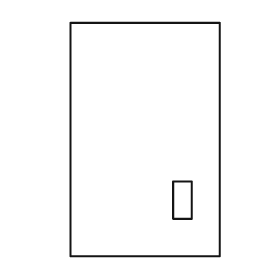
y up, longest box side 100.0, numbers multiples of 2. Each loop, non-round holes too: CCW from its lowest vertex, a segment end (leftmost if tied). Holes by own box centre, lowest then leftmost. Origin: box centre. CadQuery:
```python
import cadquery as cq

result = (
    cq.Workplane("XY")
    .moveTo(-32.0, -50.0)
    .lineTo(32.0, -50.0)
    .lineTo(32.0, 50.0)
    .lineTo(-32.0, 50.0)
    .close()
    .moveTo(12.0, -34.0)
    .lineTo(20.0, -34.0)
    .lineTo(20.0, -18.0)
    .lineTo(12.0, -18.0)
    .close()
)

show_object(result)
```